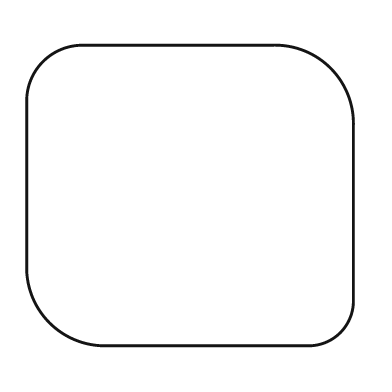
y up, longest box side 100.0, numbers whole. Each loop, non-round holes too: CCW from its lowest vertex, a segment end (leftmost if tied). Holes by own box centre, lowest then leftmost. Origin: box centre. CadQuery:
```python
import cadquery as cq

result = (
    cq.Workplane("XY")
    .moveTo(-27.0, -46.0)
    .lineTo(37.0, -46.0)
    .threePointArc((46.0, -42.0), (50.0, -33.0))
    .lineTo(50.0, 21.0)
    .threePointArc((43.0, 39.0), (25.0, 46.0))
    .lineTo(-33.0, 46.0)
    .threePointArc((-45.0, 41.0), (-50.0, 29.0))
    .lineTo(-50.0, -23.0)
    .threePointArc((-43.0, -39.0), (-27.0, -46.0))
    .close()
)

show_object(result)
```